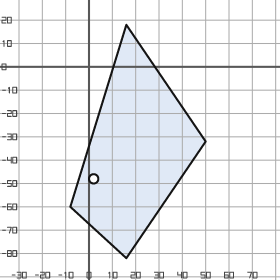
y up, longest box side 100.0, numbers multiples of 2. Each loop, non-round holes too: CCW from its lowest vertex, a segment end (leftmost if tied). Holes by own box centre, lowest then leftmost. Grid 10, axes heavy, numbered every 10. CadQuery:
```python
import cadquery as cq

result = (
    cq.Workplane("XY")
    .moveTo(16.0, -82.0)
    .lineTo(50.0, -32.0)
    .lineTo(16.0, 18.0)
    .lineTo(-8.0, -60.0)
    .close()
    .moveTo(2.0, -48.0)
    .circle(2.0)
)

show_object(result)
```